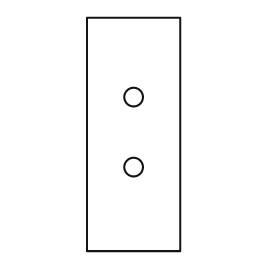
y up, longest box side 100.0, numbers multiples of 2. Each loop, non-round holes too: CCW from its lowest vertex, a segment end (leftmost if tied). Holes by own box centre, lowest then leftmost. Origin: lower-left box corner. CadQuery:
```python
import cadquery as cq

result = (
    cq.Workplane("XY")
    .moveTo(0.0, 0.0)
    .lineTo(40.0, 0.0)
    .lineTo(40.0, 100.0)
    .lineTo(0.0, 100.0)
    .close()
    .moveTo(20.0, 36.0)
    .circle(4.0)
    .moveTo(20.0, 66.0)
    .circle(4.0)
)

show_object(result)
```